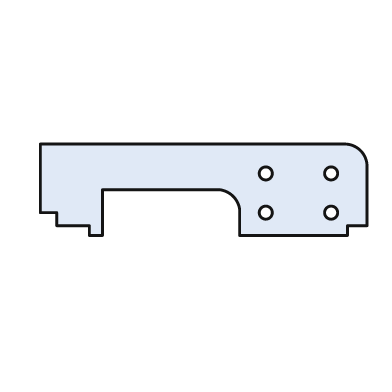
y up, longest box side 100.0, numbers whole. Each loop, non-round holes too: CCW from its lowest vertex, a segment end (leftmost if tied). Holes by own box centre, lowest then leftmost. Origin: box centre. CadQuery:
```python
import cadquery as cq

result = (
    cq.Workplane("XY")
    .moveTo(-35.0, -14.0)
    .lineTo(-31.0, -14.0)
    .lineTo(-31.0, 0.0)
    .lineTo(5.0, 0.0)
    .threePointArc((9.0, -2.0), (11.0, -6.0))
    .lineTo(11.0, -14.0)
    .lineTo(44.0, -14.0)
    .lineTo(44.0, -11.0)
    .lineTo(50.0, -11.0)
    .lineTo(50.0, 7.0)
    .threePointArc((48.0, 12.0), (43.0, 14.0))
    .lineTo(-50.0, 14.0)
    .lineTo(-50.0, -7.0)
    .lineTo(-45.0, -7.0)
    .lineTo(-45.0, -11.0)
    .lineTo(-35.0, -11.0)
    .close()
    .moveTo(19.0, -7.0)
    .circle(2.0)
    .moveTo(39.0, -7.0)
    .circle(2.0)
    .moveTo(19.0, 5.0)
    .circle(2.0)
    .moveTo(39.0, 5.0)
    .circle(2.0)
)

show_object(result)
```